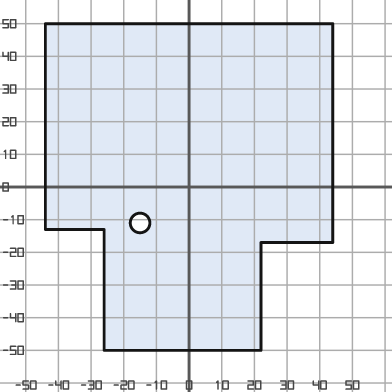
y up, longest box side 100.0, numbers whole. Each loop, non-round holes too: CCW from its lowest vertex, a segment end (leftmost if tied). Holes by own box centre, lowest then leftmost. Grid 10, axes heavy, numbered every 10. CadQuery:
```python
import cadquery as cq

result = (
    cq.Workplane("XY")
    .moveTo(-26.0, -50.0)
    .lineTo(22.0, -50.0)
    .lineTo(22.0, -17.0)
    .lineTo(44.0, -17.0)
    .lineTo(44.0, 50.0)
    .lineTo(-44.0, 50.0)
    .lineTo(-44.0, -13.0)
    .lineTo(-26.0, -13.0)
    .close()
    .moveTo(-15.0, -11.0)
    .circle(3.0)
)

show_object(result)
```